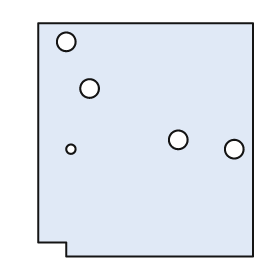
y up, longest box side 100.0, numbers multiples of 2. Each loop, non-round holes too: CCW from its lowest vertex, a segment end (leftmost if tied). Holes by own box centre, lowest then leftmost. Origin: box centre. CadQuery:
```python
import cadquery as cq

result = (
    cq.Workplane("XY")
    .moveTo(-34.0, -50.0)
    .lineTo(46.0, -50.0)
    .lineTo(46.0, 50.0)
    .lineTo(-46.0, 50.0)
    .lineTo(-46.0, -44.0)
    .lineTo(-34.0, -44.0)
    .close()
    .moveTo(-32.0, -4.0)
    .circle(2.0)
    .moveTo(38.0, -4.0)
    .circle(4.0)
    .moveTo(14.0, 0.0)
    .circle(4.0)
    .moveTo(-24.0, 22.0)
    .circle(4.0)
    .moveTo(-34.0, 42.0)
    .circle(4.0)
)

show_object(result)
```